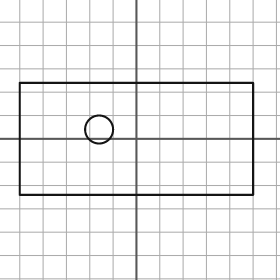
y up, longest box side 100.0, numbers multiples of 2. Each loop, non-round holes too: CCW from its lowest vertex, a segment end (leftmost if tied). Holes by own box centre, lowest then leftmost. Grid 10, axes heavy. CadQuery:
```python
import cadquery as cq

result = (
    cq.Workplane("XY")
    .moveTo(-50.0, -24.0)
    .lineTo(50.0, -24.0)
    .lineTo(50.0, 24.0)
    .lineTo(-50.0, 24.0)
    .close()
    .moveTo(-16.0, 4.0)
    .circle(6.0)
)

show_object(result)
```